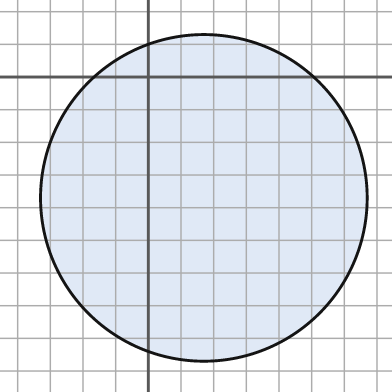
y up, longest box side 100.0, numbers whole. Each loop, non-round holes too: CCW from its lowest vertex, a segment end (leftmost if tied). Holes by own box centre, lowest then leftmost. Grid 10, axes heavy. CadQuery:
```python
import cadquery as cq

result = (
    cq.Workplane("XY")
    .moveTo(17.0, -37.0)
    .circle(50.0)
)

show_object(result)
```